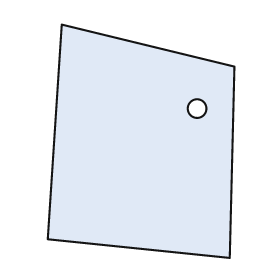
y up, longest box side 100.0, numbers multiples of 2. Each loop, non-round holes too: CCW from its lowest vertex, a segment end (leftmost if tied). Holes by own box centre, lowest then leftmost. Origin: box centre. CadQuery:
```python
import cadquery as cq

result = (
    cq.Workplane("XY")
    .moveTo(38.0, -50.0)
    .lineTo(40.0, 32.0)
    .lineTo(-34.0, 50.0)
    .lineTo(-40.0, -42.0)
    .close()
    .moveTo(24.0, 14.0)
    .circle(4.0)
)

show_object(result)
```